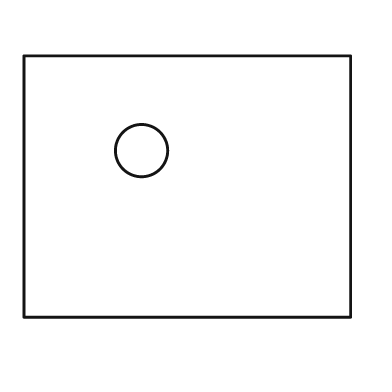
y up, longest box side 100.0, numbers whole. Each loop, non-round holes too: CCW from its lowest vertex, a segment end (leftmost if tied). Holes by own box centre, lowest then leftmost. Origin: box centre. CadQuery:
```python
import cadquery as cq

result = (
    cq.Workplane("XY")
    .moveTo(-50.0, -40.0)
    .lineTo(50.0, -40.0)
    .lineTo(50.0, 40.0)
    .lineTo(-50.0, 40.0)
    .close()
    .moveTo(-14.0, 11.0)
    .circle(8.0)
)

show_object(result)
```